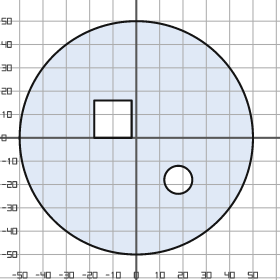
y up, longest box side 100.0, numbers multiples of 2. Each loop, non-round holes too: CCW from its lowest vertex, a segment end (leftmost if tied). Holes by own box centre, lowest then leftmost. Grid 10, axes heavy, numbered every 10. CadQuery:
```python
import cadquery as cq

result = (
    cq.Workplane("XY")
    .moveTo(0.0, 0.0)
    .circle(50.0)
    .moveTo(18.0, -18.0)
    .circle(6.0)
    .moveTo(-18.0, 0.0)
    .lineTo(-2.0, 0.0)
    .lineTo(-2.0, 16.0)
    .lineTo(-18.0, 16.0)
    .close()
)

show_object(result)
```